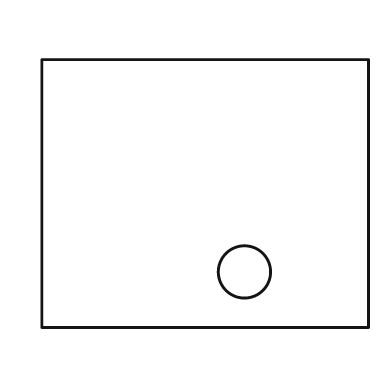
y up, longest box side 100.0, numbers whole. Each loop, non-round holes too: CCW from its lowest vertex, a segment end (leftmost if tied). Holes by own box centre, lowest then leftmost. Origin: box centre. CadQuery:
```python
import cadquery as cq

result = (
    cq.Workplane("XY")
    .moveTo(-50.0, -41.0)
    .lineTo(50.0, -41.0)
    .lineTo(50.0, 41.0)
    .lineTo(-50.0, 41.0)
    .close()
    .moveTo(12.0, -24.0)
    .circle(8.0)
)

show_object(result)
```